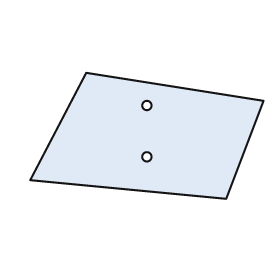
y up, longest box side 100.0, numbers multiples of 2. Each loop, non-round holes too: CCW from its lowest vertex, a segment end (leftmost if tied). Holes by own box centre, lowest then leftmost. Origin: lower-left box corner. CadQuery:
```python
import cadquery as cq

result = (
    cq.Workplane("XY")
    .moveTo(84.0, 0.0)
    .lineTo(100.0, 42.0)
    .lineTo(24.0, 54.0)
    .lineTo(0.0, 8.0)
    .close()
    .moveTo(50.0, 18.0)
    .circle(2.0)
    .moveTo(50.0, 40.0)
    .circle(2.0)
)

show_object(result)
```